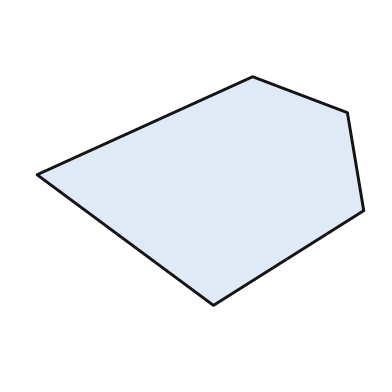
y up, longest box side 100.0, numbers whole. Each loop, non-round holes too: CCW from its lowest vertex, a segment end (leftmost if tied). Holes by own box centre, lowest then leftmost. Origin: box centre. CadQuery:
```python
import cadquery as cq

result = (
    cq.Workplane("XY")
    .moveTo(4.0, -35.0)
    .lineTo(50.0, -6.0)
    .lineTo(45.0, 24.0)
    .lineTo(16.0, 35.0)
    .lineTo(-50.0, 5.0)
    .close()
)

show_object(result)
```